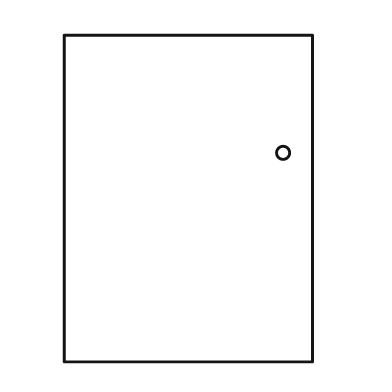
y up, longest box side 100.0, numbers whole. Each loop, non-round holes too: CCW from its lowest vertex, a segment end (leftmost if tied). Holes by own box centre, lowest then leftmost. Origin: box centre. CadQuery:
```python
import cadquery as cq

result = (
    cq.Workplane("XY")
    .moveTo(-38.0, -50.0)
    .lineTo(38.0, -50.0)
    .lineTo(38.0, 50.0)
    .lineTo(-38.0, 50.0)
    .close()
    .moveTo(29.0, 14.0)
    .circle(2.0)
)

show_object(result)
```